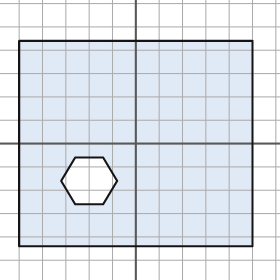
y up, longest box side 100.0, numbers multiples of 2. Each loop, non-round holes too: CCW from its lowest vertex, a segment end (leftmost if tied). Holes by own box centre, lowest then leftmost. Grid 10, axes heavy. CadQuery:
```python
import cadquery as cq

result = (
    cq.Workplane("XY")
    .moveTo(-50.0, -44.0)
    .lineTo(50.0, -44.0)
    .lineTo(50.0, 44.0)
    .lineTo(-50.0, 44.0)
    .close()
    .moveTo(-26.0, -26.0)
    .lineTo(-14.0, -26.0)
    .lineTo(-8.0, -16.0)
    .lineTo(-14.0, -6.0)
    .lineTo(-26.0, -6.0)
    .lineTo(-32.0, -16.0)
    .close()
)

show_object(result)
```